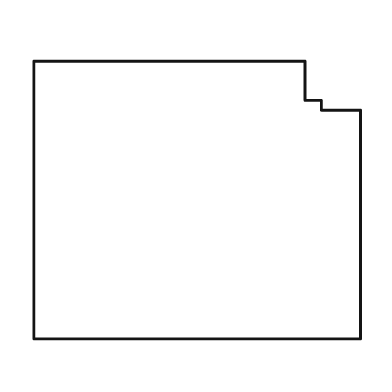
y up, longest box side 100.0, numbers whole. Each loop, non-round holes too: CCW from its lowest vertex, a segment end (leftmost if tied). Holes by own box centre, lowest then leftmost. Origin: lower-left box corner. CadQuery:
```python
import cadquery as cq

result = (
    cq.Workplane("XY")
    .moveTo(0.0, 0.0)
    .lineTo(100.0, 0.0)
    .lineTo(100.0, 70.0)
    .lineTo(88.0, 70.0)
    .lineTo(88.0, 73.0)
    .lineTo(83.0, 73.0)
    .lineTo(83.0, 85.0)
    .lineTo(0.0, 85.0)
    .close()
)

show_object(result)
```